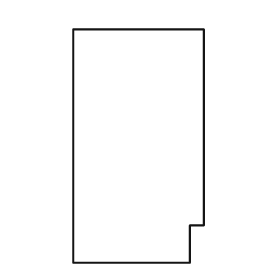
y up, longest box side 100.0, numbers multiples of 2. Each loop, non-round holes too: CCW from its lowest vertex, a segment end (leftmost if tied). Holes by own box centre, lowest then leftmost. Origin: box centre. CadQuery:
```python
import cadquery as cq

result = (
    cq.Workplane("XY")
    .moveTo(-28.0, -50.0)
    .lineTo(22.0, -50.0)
    .lineTo(22.0, -34.0)
    .lineTo(28.0, -34.0)
    .lineTo(28.0, 50.0)
    .lineTo(-28.0, 50.0)
    .close()
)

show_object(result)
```